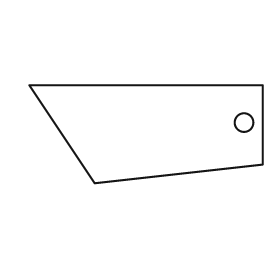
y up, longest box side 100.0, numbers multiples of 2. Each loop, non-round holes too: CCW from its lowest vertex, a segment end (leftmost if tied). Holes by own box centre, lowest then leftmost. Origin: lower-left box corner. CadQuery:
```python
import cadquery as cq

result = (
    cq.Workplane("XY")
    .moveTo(28.0, 0.0)
    .lineTo(100.0, 8.0)
    .lineTo(100.0, 42.0)
    .lineTo(0.0, 42.0)
    .close()
    .moveTo(92.0, 26.0)
    .circle(4.0)
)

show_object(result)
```